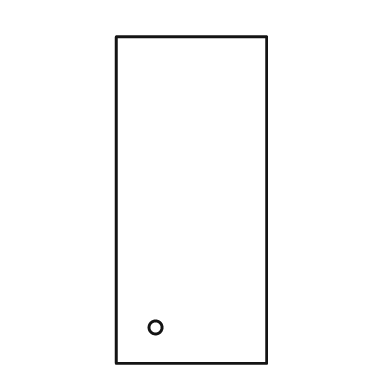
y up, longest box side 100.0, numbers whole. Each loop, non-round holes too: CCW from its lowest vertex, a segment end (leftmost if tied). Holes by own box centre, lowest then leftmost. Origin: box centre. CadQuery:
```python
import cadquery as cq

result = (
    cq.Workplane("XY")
    .moveTo(-23.0, -50.0)
    .lineTo(23.0, -50.0)
    .lineTo(23.0, 50.0)
    .lineTo(-23.0, 50.0)
    .close()
    .moveTo(-11.0, -39.0)
    .circle(2.0)
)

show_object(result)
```